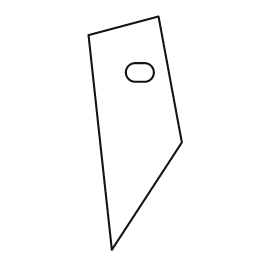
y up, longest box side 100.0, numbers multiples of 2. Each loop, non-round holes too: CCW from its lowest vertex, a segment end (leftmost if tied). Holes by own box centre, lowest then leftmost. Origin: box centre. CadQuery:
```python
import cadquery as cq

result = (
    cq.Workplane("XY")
    .moveTo(-10.0, -50.0)
    .lineTo(20.0, -4.0)
    .lineTo(10.0, 50.0)
    .lineTo(-20.0, 42.0)
    .close()
    .moveTo(0.0, 22.0)
    .lineTo(4.0, 22.0)
    .threePointArc((8.0, 26.0), (4.0, 30.0))
    .lineTo(0.0, 30.0)
    .threePointArc((-4.0, 26.0), (0.0, 22.0))
    .close()
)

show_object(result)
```